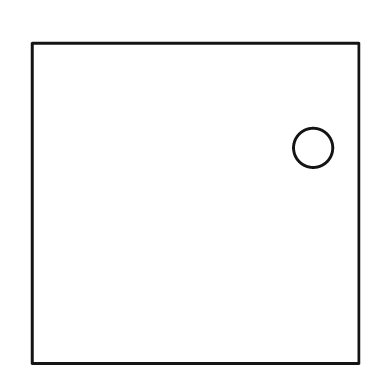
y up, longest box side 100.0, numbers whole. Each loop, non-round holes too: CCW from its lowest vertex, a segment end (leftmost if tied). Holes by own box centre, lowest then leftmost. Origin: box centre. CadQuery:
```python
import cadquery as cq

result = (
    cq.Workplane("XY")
    .moveTo(-50.0, -49.0)
    .lineTo(50.0, -49.0)
    .lineTo(50.0, 49.0)
    .lineTo(-50.0, 49.0)
    .close()
    .moveTo(36.0, 17.0)
    .circle(6.0)
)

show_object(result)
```